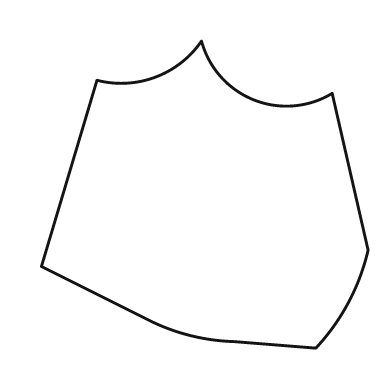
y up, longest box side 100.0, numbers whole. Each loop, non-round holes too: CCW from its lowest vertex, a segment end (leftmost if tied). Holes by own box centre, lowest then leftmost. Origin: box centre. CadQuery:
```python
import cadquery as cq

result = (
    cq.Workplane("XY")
    .moveTo(34.0, -47.0)
    .threePointArc((44.0, -33.0), (50.0, -17.0))
    .lineTo(39.0, 31.0)
    .threePointArc((15.0, 29.0), (-1.0, 47.0))
    .threePointArc((-15.0, 36.0), (-33.0, 35.0))
    .lineTo(-50.0, -22.0)
    .lineTo(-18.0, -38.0)
    .threePointArc((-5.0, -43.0), (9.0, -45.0))
    .close()
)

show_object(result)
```